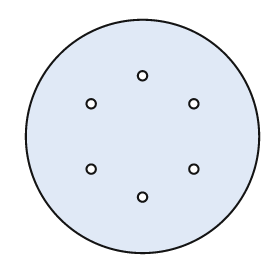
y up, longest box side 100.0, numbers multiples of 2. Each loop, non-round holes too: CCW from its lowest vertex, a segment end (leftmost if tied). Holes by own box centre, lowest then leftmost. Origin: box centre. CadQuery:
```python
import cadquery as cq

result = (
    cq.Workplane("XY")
    .moveTo(0.0, 0.0)
    .circle(50.0)
    .moveTo(0.0, -26.0)
    .circle(2.0)
    .moveTo(-22.0, -14.0)
    .circle(2.0)
    .moveTo(22.0, -14.0)
    .circle(2.0)
    .moveTo(-22.0, 14.0)
    .circle(2.0)
    .moveTo(22.0, 14.0)
    .circle(2.0)
    .moveTo(0.0, 26.0)
    .circle(2.0)
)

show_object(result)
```